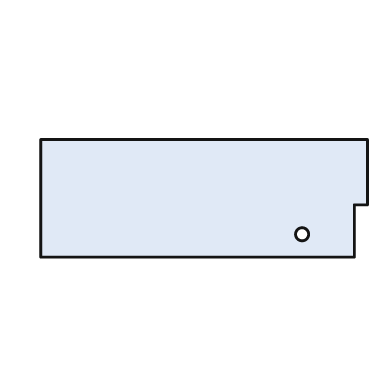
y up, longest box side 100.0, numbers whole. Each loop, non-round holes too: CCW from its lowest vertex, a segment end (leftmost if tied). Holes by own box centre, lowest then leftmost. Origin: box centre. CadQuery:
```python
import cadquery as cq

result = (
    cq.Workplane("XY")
    .moveTo(-50.0, -18.0)
    .lineTo(46.0, -18.0)
    .lineTo(46.0, -2.0)
    .lineTo(50.0, -2.0)
    .lineTo(50.0, 18.0)
    .lineTo(-50.0, 18.0)
    .close()
    .moveTo(30.0, -11.0)
    .circle(2.0)
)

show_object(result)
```